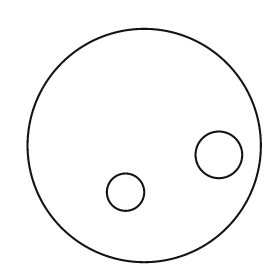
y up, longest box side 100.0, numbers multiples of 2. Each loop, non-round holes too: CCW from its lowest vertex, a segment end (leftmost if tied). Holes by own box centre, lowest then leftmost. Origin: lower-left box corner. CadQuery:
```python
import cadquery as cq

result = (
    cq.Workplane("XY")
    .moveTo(50.0, 50.0)
    .circle(50.0)
    .moveTo(42.0, 30.0)
    .circle(8.0)
    .moveTo(82.0, 46.0)
    .circle(10.0)
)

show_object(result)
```